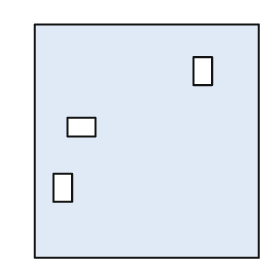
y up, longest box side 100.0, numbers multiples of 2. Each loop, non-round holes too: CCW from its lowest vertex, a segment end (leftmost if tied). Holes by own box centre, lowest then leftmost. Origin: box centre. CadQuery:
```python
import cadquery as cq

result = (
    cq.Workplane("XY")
    .moveTo(-48.0, -50.0)
    .lineTo(48.0, -50.0)
    .lineTo(48.0, 50.0)
    .lineTo(-48.0, 50.0)
    .close()
    .moveTo(-40.0, -26.0)
    .lineTo(-32.0, -26.0)
    .lineTo(-32.0, -14.0)
    .lineTo(-40.0, -14.0)
    .close()
    .moveTo(-34.0, 2.0)
    .lineTo(-22.0, 2.0)
    .lineTo(-22.0, 10.0)
    .lineTo(-34.0, 10.0)
    .close()
    .moveTo(20.0, 24.0)
    .lineTo(28.0, 24.0)
    .lineTo(28.0, 36.0)
    .lineTo(20.0, 36.0)
    .close()
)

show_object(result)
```